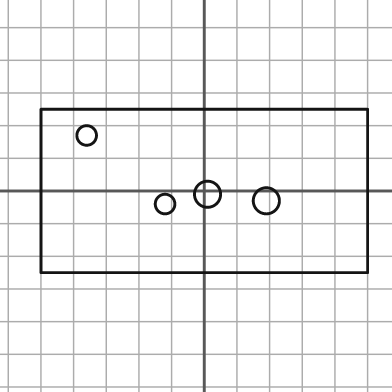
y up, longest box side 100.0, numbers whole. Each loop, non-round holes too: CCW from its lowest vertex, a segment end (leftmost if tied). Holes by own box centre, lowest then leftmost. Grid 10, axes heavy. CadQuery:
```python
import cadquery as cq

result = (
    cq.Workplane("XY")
    .moveTo(-50.0, -25.0)
    .lineTo(50.0, -25.0)
    .lineTo(50.0, 25.0)
    .lineTo(-50.0, 25.0)
    .close()
    .moveTo(-12.0, -4.0)
    .circle(3.0)
    .moveTo(19.0, -3.0)
    .circle(4.0)
    .moveTo(1.0, -1.0)
    .circle(4.0)
    .moveTo(-36.0, 17.0)
    .circle(3.0)
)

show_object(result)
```